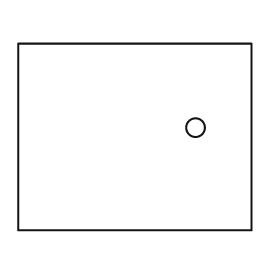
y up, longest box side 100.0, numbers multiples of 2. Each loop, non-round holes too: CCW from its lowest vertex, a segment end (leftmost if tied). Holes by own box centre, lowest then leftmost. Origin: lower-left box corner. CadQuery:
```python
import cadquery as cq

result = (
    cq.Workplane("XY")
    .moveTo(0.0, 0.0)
    .lineTo(100.0, 0.0)
    .lineTo(100.0, 80.0)
    .lineTo(0.0, 80.0)
    .close()
    .moveTo(76.0, 44.0)
    .circle(4.0)
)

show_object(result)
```